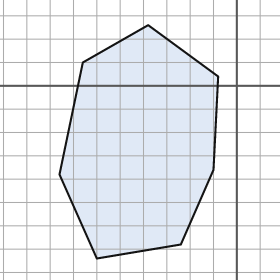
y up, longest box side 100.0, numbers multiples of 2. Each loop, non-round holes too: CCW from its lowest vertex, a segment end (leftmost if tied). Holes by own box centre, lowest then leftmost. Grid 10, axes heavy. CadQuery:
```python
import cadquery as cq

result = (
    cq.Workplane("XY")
    .moveTo(-60.0, -74.0)
    .lineTo(-24.0, -68.0)
    .lineTo(-10.0, -36.0)
    .lineTo(-8.0, 4.0)
    .lineTo(-38.0, 26.0)
    .lineTo(-66.0, 10.0)
    .lineTo(-76.0, -38.0)
    .close()
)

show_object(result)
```